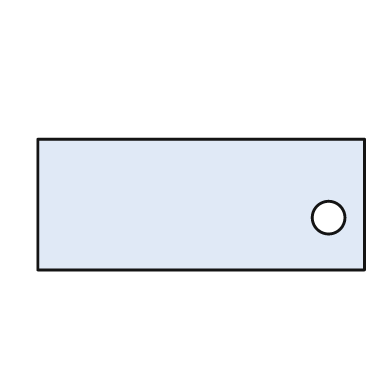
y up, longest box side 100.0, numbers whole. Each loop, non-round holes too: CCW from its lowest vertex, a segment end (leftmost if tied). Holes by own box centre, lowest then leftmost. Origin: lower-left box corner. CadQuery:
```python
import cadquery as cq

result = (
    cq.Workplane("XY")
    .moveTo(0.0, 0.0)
    .lineTo(100.0, 0.0)
    .lineTo(100.0, 40.0)
    .lineTo(0.0, 40.0)
    .close()
    .moveTo(89.0, 16.0)
    .circle(5.0)
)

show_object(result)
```